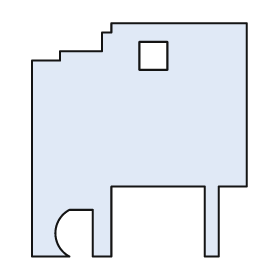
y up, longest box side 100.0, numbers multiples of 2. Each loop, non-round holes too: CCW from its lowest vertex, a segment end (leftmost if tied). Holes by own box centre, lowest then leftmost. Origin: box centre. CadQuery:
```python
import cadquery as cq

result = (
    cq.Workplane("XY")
    .moveTo(-46.0, -50.0)
    .lineTo(-30.0, -50.0)
    .threePointArc((-36.0, -40.0), (-30.0, -30.0))
    .lineTo(-20.0, -30.0)
    .lineTo(-20.0, -50.0)
    .lineTo(-12.0, -50.0)
    .lineTo(-12.0, -20.0)
    .lineTo(28.0, -20.0)
    .lineTo(28.0, -50.0)
    .lineTo(34.0, -50.0)
    .lineTo(34.0, -20.0)
    .lineTo(46.0, -20.0)
    .lineTo(46.0, 50.0)
    .lineTo(-12.0, 50.0)
    .lineTo(-12.0, 46.0)
    .lineTo(-16.0, 46.0)
    .lineTo(-16.0, 38.0)
    .lineTo(-34.0, 38.0)
    .lineTo(-34.0, 34.0)
    .lineTo(-46.0, 34.0)
    .close()
    .moveTo(0.0, 30.0)
    .lineTo(12.0, 30.0)
    .lineTo(12.0, 42.0)
    .lineTo(0.0, 42.0)
    .close()
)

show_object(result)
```